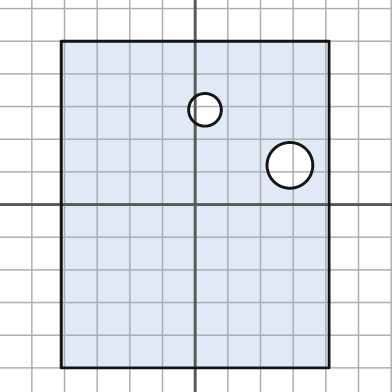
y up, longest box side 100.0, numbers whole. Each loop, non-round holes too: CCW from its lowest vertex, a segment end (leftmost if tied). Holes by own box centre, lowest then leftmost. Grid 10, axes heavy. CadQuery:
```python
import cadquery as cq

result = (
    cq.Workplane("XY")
    .moveTo(-41.0, -50.0)
    .lineTo(41.0, -50.0)
    .lineTo(41.0, 50.0)
    .lineTo(-41.0, 50.0)
    .close()
    .moveTo(29.0, 12.0)
    .circle(7.0)
    .moveTo(3.0, 29.0)
    .circle(5.0)
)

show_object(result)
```